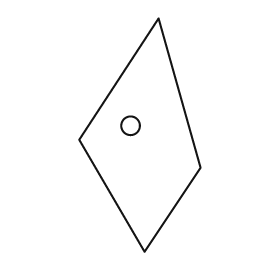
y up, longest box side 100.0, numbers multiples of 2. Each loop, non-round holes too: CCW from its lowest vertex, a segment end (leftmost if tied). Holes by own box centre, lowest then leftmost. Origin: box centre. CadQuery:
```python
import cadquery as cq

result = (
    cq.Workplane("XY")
    .moveTo(2.0, -50.0)
    .lineTo(26.0, -14.0)
    .lineTo(8.0, 50.0)
    .lineTo(-26.0, -2.0)
    .close()
    .moveTo(-4.0, 4.0)
    .circle(4.0)
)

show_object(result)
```